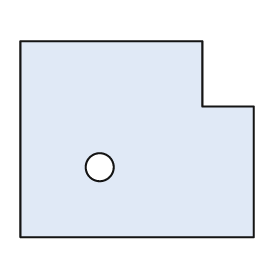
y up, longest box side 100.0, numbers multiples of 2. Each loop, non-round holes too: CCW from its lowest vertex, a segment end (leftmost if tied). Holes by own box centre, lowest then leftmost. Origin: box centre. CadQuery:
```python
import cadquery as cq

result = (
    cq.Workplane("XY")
    .moveTo(-50.0, -42.0)
    .lineTo(50.0, -42.0)
    .lineTo(50.0, 14.0)
    .lineTo(28.0, 14.0)
    .lineTo(28.0, 42.0)
    .lineTo(-50.0, 42.0)
    .close()
    .moveTo(-16.0, -12.0)
    .circle(6.0)
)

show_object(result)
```